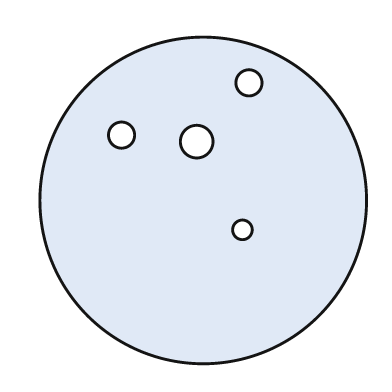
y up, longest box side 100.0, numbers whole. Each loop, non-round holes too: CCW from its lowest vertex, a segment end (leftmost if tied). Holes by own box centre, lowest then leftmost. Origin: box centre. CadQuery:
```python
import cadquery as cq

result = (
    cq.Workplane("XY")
    .moveTo(0.0, 0.0)
    .circle(50.0)
    .moveTo(12.0, -9.0)
    .circle(3.0)
    .moveTo(-2.0, 18.0)
    .circle(5.0)
    .moveTo(-25.0, 20.0)
    .circle(4.0)
    .moveTo(14.0, 36.0)
    .circle(4.0)
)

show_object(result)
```